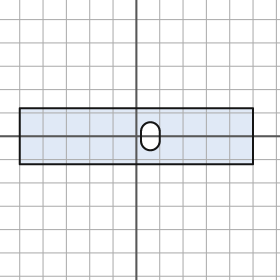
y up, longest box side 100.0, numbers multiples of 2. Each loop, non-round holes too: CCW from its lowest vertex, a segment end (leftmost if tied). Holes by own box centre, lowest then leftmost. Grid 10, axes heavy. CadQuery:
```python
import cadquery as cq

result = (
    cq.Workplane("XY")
    .moveTo(-50.0, -12.0)
    .lineTo(50.0, -12.0)
    .lineTo(50.0, 12.0)
    .lineTo(-50.0, 12.0)
    .close()
    .moveTo(2.0, -2.0)
    .threePointArc((6.0, -6.0), (10.0, -2.0))
    .lineTo(10.0, 2.0)
    .threePointArc((6.0, 6.0), (2.0, 2.0))
    .close()
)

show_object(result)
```